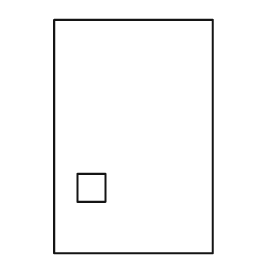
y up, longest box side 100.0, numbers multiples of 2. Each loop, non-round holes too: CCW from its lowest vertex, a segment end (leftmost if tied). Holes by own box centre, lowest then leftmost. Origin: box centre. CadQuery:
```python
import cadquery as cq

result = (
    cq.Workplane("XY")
    .moveTo(-34.0, -50.0)
    .lineTo(34.0, -50.0)
    .lineTo(34.0, 50.0)
    .lineTo(-34.0, 50.0)
    .close()
    .moveTo(-24.0, -28.0)
    .lineTo(-12.0, -28.0)
    .lineTo(-12.0, -16.0)
    .lineTo(-24.0, -16.0)
    .close()
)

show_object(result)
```